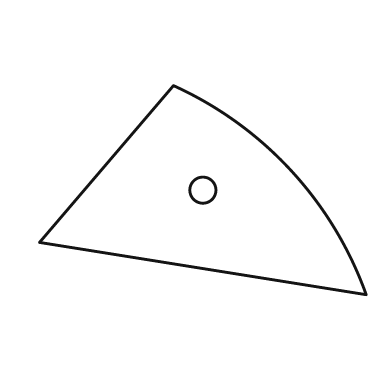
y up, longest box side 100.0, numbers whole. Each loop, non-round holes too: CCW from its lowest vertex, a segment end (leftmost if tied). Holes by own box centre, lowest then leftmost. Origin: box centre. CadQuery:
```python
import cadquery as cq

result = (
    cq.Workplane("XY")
    .moveTo(50.0, -32.0)
    .threePointArc((27.0, 6.0), (-9.0, 32.0))
    .lineTo(-50.0, -16.0)
    .close()
    .moveTo(0.0, 0.0)
    .circle(4.0)
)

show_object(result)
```